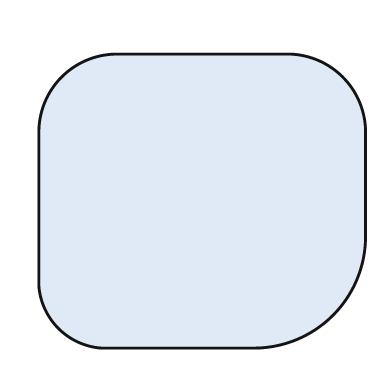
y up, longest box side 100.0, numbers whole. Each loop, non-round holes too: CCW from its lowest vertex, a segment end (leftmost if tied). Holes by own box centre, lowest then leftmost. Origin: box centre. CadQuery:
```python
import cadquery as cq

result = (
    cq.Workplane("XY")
    .moveTo(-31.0, -45.0)
    .lineTo(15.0, -45.0)
    .threePointArc((40.0, -35.0), (50.0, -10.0))
    .lineTo(50.0, 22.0)
    .threePointArc((43.0, 38.0), (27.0, 45.0))
    .lineTo(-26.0, 45.0)
    .threePointArc((-43.0, 38.0), (-50.0, 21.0))
    .lineTo(-50.0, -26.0)
    .threePointArc((-44.0, -39.0), (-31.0, -45.0))
    .close()
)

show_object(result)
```